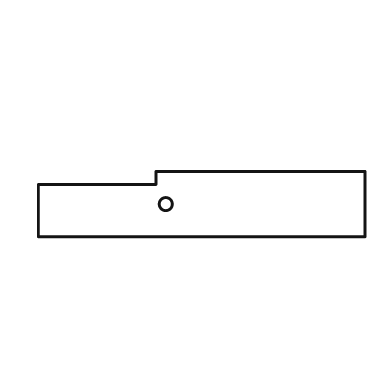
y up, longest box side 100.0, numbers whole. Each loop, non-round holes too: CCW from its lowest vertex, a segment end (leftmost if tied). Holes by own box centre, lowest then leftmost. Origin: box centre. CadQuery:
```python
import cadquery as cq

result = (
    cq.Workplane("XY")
    .moveTo(-50.0, -10.0)
    .lineTo(50.0, -10.0)
    .lineTo(50.0, 10.0)
    .lineTo(-14.0, 10.0)
    .lineTo(-14.0, 6.0)
    .lineTo(-50.0, 6.0)
    .close()
    .moveTo(-11.0, 0.0)
    .circle(2.0)
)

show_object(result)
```